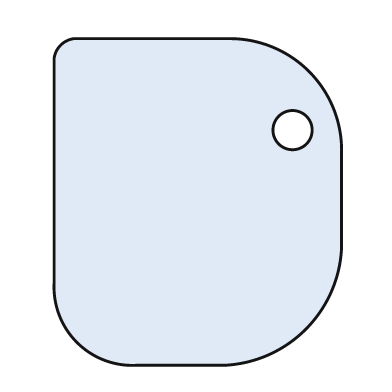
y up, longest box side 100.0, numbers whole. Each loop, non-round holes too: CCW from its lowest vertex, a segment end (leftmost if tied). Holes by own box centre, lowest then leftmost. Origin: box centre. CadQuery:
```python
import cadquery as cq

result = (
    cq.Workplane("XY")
    .moveTo(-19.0, -50.0)
    .lineTo(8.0, -50.0)
    .threePointArc((33.0, -39.0), (44.0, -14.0))
    .lineTo(44.0, 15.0)
    .threePointArc((34.0, 40.0), (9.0, 50.0))
    .lineTo(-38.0, 50.0)
    .threePointArc((-42.0, 48.0), (-44.0, 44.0))
    .lineTo(-44.0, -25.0)
    .threePointArc((-37.0, -43.0), (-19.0, -50.0))
    .close()
    .moveTo(29.0, 22.0)
    .circle(6.0)
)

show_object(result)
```